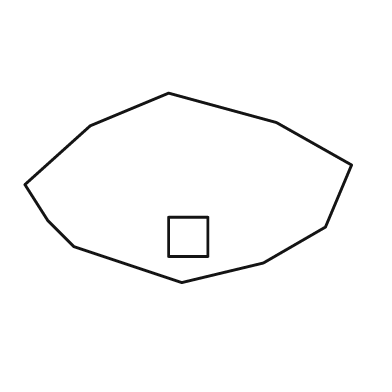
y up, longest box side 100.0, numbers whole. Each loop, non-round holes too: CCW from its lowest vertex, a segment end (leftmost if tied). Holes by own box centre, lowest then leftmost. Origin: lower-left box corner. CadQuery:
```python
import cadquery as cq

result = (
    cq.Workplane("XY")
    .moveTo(48.0, 0.0)
    .lineTo(73.0, 6.0)
    .lineTo(92.0, 17.0)
    .lineTo(100.0, 36.0)
    .lineTo(77.0, 49.0)
    .lineTo(44.0, 58.0)
    .lineTo(20.0, 48.0)
    .lineTo(0.0, 30.0)
    .lineTo(7.0, 19.0)
    .lineTo(15.0, 11.0)
    .close()
    .moveTo(44.0, 8.0)
    .lineTo(56.0, 8.0)
    .lineTo(56.0, 20.0)
    .lineTo(44.0, 20.0)
    .close()
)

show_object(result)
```